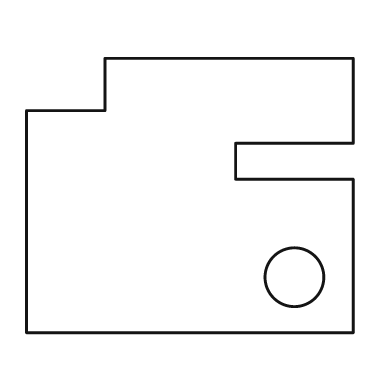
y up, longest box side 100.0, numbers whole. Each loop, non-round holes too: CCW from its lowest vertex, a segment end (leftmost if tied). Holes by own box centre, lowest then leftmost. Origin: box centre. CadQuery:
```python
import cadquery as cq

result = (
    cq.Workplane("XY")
    .moveTo(-50.0, -42.0)
    .lineTo(50.0, -42.0)
    .lineTo(50.0, 5.0)
    .lineTo(14.0, 5.0)
    .lineTo(14.0, 16.0)
    .lineTo(50.0, 16.0)
    .lineTo(50.0, 42.0)
    .lineTo(-26.0, 42.0)
    .lineTo(-26.0, 26.0)
    .lineTo(-50.0, 26.0)
    .close()
    .moveTo(32.0, -25.0)
    .circle(9.0)
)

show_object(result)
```